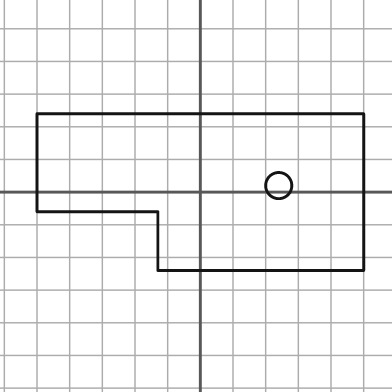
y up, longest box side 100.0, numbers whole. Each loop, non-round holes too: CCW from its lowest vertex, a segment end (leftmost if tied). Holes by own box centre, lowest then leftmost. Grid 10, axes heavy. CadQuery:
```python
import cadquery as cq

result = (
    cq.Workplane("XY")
    .moveTo(-13.0, -24.0)
    .lineTo(50.0, -24.0)
    .lineTo(50.0, 24.0)
    .lineTo(-50.0, 24.0)
    .lineTo(-50.0, -6.0)
    .lineTo(-13.0, -6.0)
    .close()
    .moveTo(24.0, 2.0)
    .circle(4.0)
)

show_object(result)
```